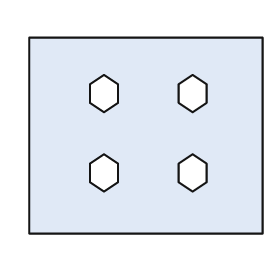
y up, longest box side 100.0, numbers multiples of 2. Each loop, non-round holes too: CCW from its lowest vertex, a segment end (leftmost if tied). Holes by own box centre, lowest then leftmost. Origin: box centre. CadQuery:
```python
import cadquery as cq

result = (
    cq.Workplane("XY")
    .moveTo(-50.0, -42.0)
    .lineTo(50.0, -42.0)
    .lineTo(50.0, 42.0)
    .lineTo(-50.0, 42.0)
    .close()
    .moveTo(-18.0, -24.0)
    .lineTo(-12.0, -20.0)
    .lineTo(-12.0, -12.0)
    .lineTo(-18.0, -8.0)
    .lineTo(-24.0, -12.0)
    .lineTo(-24.0, -20.0)
    .close()
    .moveTo(20.0, -24.0)
    .lineTo(26.0, -20.0)
    .lineTo(26.0, -12.0)
    .lineTo(20.0, -8.0)
    .lineTo(14.0, -12.0)
    .lineTo(14.0, -20.0)
    .close()
    .moveTo(-18.0, 10.0)
    .lineTo(-12.0, 14.0)
    .lineTo(-12.0, 22.0)
    .lineTo(-18.0, 26.0)
    .lineTo(-24.0, 22.0)
    .lineTo(-24.0, 14.0)
    .close()
    .moveTo(20.0, 10.0)
    .lineTo(26.0, 14.0)
    .lineTo(26.0, 22.0)
    .lineTo(20.0, 26.0)
    .lineTo(14.0, 22.0)
    .lineTo(14.0, 14.0)
    .close()
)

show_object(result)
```